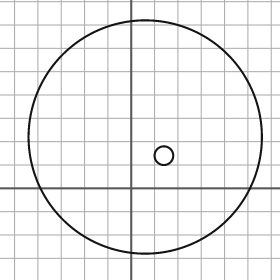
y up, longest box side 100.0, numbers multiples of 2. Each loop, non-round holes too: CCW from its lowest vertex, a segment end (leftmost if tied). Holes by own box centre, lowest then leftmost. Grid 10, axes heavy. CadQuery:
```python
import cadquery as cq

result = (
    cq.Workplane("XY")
    .moveTo(6.0, 22.0)
    .circle(50.0)
    .moveTo(14.0, 14.0)
    .circle(4.0)
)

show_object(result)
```